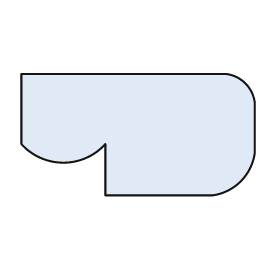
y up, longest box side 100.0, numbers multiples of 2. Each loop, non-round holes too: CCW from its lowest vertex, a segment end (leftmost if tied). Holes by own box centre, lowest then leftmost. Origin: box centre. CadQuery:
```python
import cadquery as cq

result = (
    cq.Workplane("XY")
    .moveTo(-14.0, -26.0)
    .lineTo(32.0, -26.0)
    .threePointArc((44.0, -20.0), (50.0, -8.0))
    .lineTo(50.0, 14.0)
    .threePointArc((46.0, 22.0), (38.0, 26.0))
    .lineTo(-50.0, 26.0)
    .lineTo(-50.0, -4.0)
    .threePointArc((-32.0, -12.0), (-14.0, -4.0))
    .close()
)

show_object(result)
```